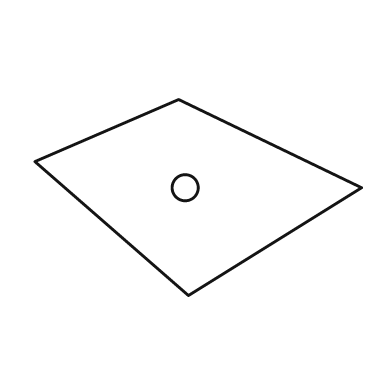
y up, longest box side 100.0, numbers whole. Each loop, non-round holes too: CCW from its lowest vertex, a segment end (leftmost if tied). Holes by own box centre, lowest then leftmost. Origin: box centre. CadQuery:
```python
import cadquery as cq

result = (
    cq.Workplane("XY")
    .moveTo(-3.0, -30.0)
    .lineTo(50.0, 3.0)
    .lineTo(-6.0, 30.0)
    .lineTo(-50.0, 11.0)
    .close()
    .moveTo(-4.0, 3.0)
    .circle(4.0)
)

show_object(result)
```